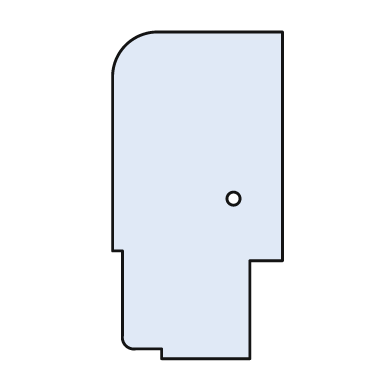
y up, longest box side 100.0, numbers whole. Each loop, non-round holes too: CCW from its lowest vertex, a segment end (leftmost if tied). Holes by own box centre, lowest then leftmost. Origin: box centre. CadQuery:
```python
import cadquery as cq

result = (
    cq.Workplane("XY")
    .moveTo(-11.0, -50.0)
    .lineTo(16.0, -50.0)
    .lineTo(16.0, -20.0)
    .lineTo(26.0, -20.0)
    .lineTo(26.0, 50.0)
    .lineTo(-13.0, 50.0)
    .threePointArc((-22.0, 46.0), (-26.0, 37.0))
    .lineTo(-26.0, -17.0)
    .lineTo(-23.0, -17.0)
    .lineTo(-23.0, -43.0)
    .threePointArc((-22.0, -46.0), (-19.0, -47.0))
    .lineTo(-11.0, -47.0)
    .close()
    .moveTo(11.0, -1.0)
    .circle(2.0)
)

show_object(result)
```